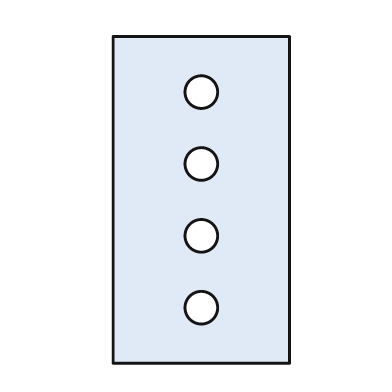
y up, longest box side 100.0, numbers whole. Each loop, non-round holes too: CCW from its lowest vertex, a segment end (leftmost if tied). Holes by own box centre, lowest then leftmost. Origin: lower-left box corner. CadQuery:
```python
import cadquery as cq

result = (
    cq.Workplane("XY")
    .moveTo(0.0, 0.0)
    .lineTo(54.0, 0.0)
    .lineTo(54.0, 100.0)
    .lineTo(0.0, 100.0)
    .close()
    .moveTo(27.0, 17.0)
    .circle(5.0)
    .moveTo(27.0, 39.0)
    .circle(5.0)
    .moveTo(27.0, 61.0)
    .circle(5.0)
    .moveTo(27.0, 83.0)
    .circle(5.0)
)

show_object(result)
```